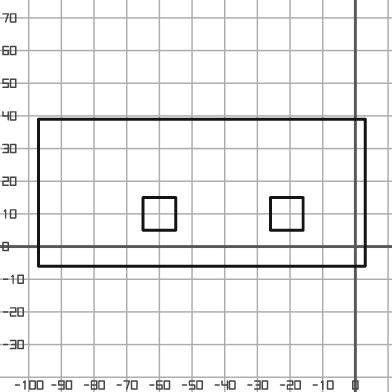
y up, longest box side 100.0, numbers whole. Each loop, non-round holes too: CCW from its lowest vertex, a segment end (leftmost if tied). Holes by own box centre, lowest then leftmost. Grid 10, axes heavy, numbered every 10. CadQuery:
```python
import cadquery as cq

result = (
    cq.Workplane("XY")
    .moveTo(-97.0, -6.0)
    .lineTo(3.0, -6.0)
    .lineTo(3.0, 39.0)
    .lineTo(-97.0, 39.0)
    .close()
    .moveTo(-65.0, 5.0)
    .lineTo(-55.0, 5.0)
    .lineTo(-55.0, 15.0)
    .lineTo(-65.0, 15.0)
    .close()
    .moveTo(-26.0, 5.0)
    .lineTo(-16.0, 5.0)
    .lineTo(-16.0, 15.0)
    .lineTo(-26.0, 15.0)
    .close()
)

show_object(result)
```